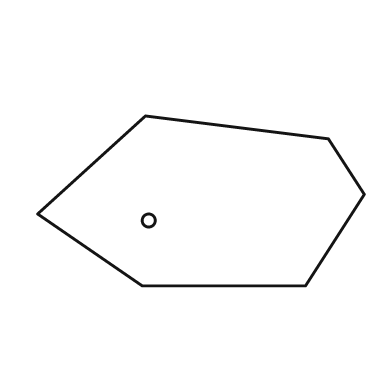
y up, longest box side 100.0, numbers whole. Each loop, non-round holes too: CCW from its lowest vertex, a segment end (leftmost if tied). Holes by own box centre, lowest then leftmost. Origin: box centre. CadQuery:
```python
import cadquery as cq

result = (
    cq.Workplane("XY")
    .moveTo(-18.0, -26.0)
    .lineTo(32.0, -26.0)
    .lineTo(50.0, 2.0)
    .lineTo(39.0, 19.0)
    .lineTo(-17.0, 26.0)
    .lineTo(-50.0, -4.0)
    .close()
    .moveTo(-16.0, -6.0)
    .circle(2.0)
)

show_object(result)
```